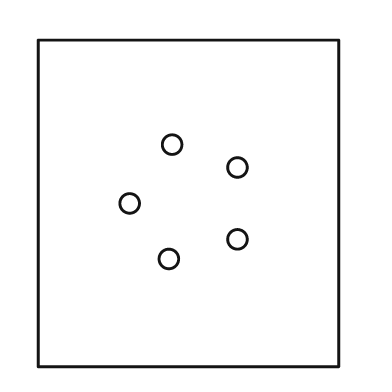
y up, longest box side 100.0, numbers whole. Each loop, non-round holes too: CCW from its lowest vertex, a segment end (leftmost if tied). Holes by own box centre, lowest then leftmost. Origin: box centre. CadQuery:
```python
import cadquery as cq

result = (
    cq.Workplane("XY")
    .moveTo(-46.0, -50.0)
    .lineTo(46.0, -50.0)
    .lineTo(46.0, 50.0)
    .lineTo(-46.0, 50.0)
    .close()
    .moveTo(-6.0, -17.0)
    .circle(3.0)
    .moveTo(15.0, -11.0)
    .circle(3.0)
    .moveTo(-18.0, 0.0)
    .circle(3.0)
    .moveTo(15.0, 11.0)
    .circle(3.0)
    .moveTo(-5.0, 18.0)
    .circle(3.0)
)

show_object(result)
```